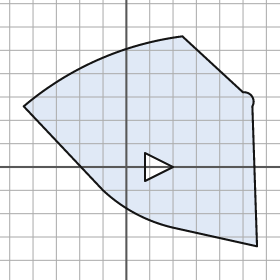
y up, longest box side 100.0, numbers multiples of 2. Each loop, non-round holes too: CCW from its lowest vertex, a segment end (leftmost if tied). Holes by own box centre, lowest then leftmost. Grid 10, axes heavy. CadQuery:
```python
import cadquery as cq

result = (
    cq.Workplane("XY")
    .moveTo(56.0, -34.0)
    .lineTo(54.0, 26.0)
    .threePointArc((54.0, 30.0), (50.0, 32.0))
    .lineTo(24.0, 56.0)
    .threePointArc((-12.0, 46.0), (-44.0, 26.0))
    .lineTo(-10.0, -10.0)
    .threePointArc((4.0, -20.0), (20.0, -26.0))
    .close()
    .moveTo(8.0, -6.0)
    .lineTo(20.0, 0.0)
    .lineTo(8.0, 6.0)
    .close()
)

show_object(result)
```